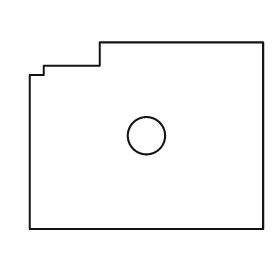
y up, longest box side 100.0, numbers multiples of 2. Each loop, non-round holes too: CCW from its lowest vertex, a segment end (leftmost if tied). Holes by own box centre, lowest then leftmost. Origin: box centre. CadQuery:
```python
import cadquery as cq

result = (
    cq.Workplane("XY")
    .moveTo(-50.0, -40.0)
    .lineTo(50.0, -40.0)
    .lineTo(50.0, 40.0)
    .lineTo(-20.0, 40.0)
    .lineTo(-20.0, 30.0)
    .lineTo(-44.0, 30.0)
    .lineTo(-44.0, 26.0)
    .lineTo(-50.0, 26.0)
    .close()
    .moveTo(0.0, 0.0)
    .circle(8.0)
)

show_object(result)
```